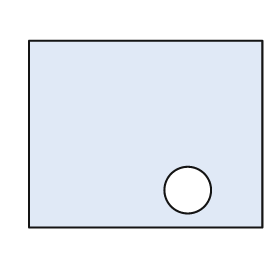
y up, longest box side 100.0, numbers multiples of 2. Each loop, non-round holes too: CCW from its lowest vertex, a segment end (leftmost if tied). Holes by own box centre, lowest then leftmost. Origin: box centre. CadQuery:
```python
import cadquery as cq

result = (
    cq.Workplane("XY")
    .moveTo(-50.0, -40.0)
    .lineTo(50.0, -40.0)
    .lineTo(50.0, 40.0)
    .lineTo(-50.0, 40.0)
    .close()
    .moveTo(18.0, -24.0)
    .circle(10.0)
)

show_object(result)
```